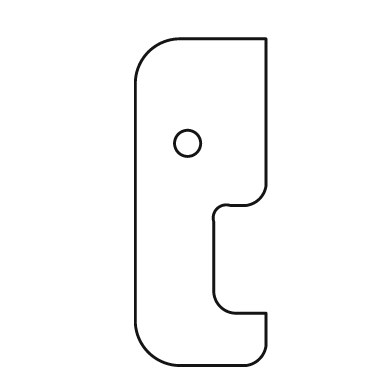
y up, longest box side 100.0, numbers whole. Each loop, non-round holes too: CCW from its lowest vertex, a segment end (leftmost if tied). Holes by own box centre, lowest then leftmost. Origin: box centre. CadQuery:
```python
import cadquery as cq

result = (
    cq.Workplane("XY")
    .moveTo(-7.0, -50.0)
    .lineTo(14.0, -50.0)
    .threePointArc((18.0, -48.0), (20.0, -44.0))
    .lineTo(20.0, -34.0)
    .lineTo(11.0, -34.0)
    .threePointArc((6.0, -32.0), (4.0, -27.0))
    .lineTo(4.0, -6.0)
    .threePointArc((5.0, -2.0), (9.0, -1.0))
    .lineTo(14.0, -1.0)
    .threePointArc((18.0, 1.0), (20.0, 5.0))
    .lineTo(20.0, 50.0)
    .lineTo(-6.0, 50.0)
    .threePointArc((-16.0, 46.0), (-20.0, 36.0))
    .lineTo(-20.0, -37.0)
    .threePointArc((-16.0, -46.0), (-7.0, -50.0))
    .close()
    .moveTo(-4.0, 18.0)
    .circle(4.0)
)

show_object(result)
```